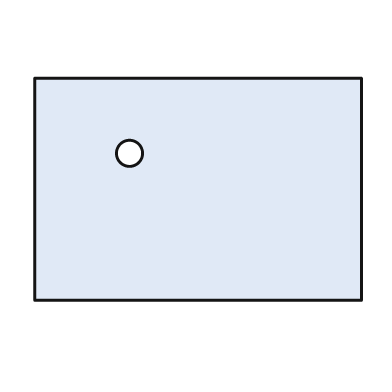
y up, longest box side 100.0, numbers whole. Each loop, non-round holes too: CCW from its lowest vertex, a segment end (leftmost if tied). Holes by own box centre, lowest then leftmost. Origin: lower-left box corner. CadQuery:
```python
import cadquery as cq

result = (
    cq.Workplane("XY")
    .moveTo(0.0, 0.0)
    .lineTo(100.0, 0.0)
    .lineTo(100.0, 68.0)
    .lineTo(0.0, 68.0)
    .close()
    .moveTo(29.0, 45.0)
    .circle(4.0)
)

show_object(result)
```